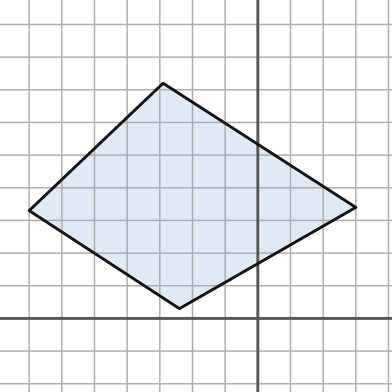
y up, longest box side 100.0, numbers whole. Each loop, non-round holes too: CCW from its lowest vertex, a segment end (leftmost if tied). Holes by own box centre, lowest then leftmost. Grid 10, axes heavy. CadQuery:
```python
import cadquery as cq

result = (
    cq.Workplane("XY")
    .moveTo(-24.0, 3.0)
    .lineTo(30.0, 34.0)
    .lineTo(-29.0, 72.0)
    .lineTo(-70.0, 33.0)
    .close()
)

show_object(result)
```